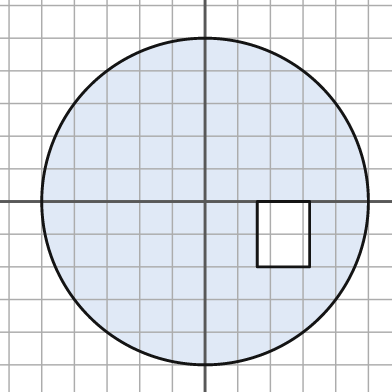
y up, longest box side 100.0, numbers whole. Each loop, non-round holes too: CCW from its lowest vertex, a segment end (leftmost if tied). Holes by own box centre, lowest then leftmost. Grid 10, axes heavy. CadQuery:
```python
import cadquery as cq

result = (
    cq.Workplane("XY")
    .moveTo(0.0, 0.0)
    .circle(50.0)
    .moveTo(16.0, -20.0)
    .lineTo(32.0, -20.0)
    .lineTo(32.0, 0.0)
    .lineTo(16.0, 0.0)
    .close()
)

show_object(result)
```